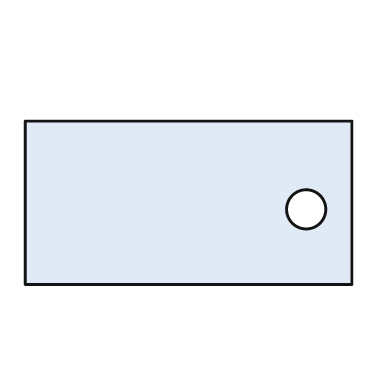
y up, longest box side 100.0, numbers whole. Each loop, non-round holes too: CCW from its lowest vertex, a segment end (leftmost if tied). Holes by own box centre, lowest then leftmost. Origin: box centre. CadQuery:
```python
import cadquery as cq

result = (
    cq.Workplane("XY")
    .moveTo(-50.0, -25.0)
    .lineTo(50.0, -25.0)
    .lineTo(50.0, 25.0)
    .lineTo(-50.0, 25.0)
    .close()
    .moveTo(36.0, -2.0)
    .circle(6.0)
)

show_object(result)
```